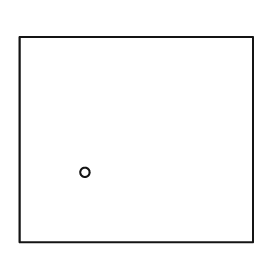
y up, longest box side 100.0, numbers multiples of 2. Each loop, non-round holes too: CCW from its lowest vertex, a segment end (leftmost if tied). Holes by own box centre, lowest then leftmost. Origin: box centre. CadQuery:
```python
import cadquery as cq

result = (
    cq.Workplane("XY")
    .moveTo(-50.0, -44.0)
    .lineTo(50.0, -44.0)
    .lineTo(50.0, 44.0)
    .lineTo(-50.0, 44.0)
    .close()
    .moveTo(-22.0, -14.0)
    .circle(2.0)
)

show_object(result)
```